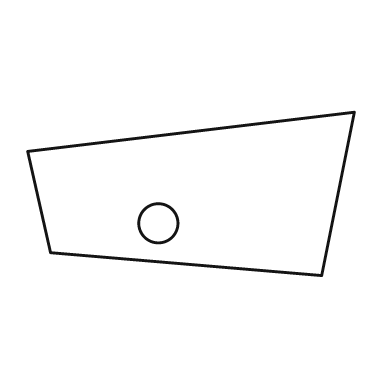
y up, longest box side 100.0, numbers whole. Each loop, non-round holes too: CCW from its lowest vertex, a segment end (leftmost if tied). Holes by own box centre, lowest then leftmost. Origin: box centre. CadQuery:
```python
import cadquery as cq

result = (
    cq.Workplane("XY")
    .moveTo(40.0, -25.0)
    .lineTo(50.0, 25.0)
    .lineTo(-50.0, 13.0)
    .lineTo(-43.0, -18.0)
    .close()
    .moveTo(-10.0, -9.0)
    .circle(6.0)
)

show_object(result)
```